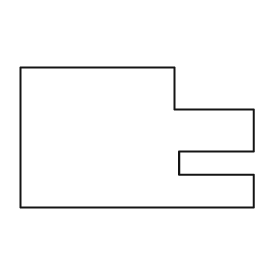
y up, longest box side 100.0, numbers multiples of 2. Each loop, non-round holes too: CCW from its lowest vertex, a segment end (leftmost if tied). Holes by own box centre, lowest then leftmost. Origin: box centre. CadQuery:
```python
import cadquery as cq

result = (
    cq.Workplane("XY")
    .moveTo(-50.0, -30.0)
    .lineTo(50.0, -30.0)
    .lineTo(50.0, -16.0)
    .lineTo(18.0, -16.0)
    .lineTo(18.0, -6.0)
    .lineTo(50.0, -6.0)
    .lineTo(50.0, 12.0)
    .lineTo(16.0, 12.0)
    .lineTo(16.0, 30.0)
    .lineTo(-50.0, 30.0)
    .close()
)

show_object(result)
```